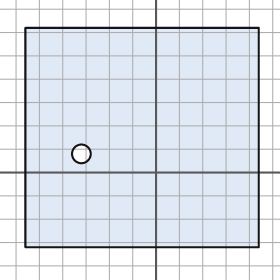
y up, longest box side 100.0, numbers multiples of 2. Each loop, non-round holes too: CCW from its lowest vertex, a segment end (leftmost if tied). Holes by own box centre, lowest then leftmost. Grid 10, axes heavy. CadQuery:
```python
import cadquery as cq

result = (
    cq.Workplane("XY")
    .moveTo(-56.0, -32.0)
    .lineTo(44.0, -32.0)
    .lineTo(44.0, 62.0)
    .lineTo(-56.0, 62.0)
    .close()
    .moveTo(-32.0, 8.0)
    .circle(4.0)
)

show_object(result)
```